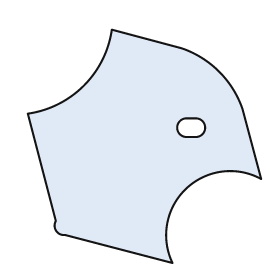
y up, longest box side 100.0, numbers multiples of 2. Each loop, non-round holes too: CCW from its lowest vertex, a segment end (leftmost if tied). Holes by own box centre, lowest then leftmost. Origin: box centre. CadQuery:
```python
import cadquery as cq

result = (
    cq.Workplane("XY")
    .moveTo(12.0, -50.0)
    .threePointArc((18.0, -18.0), (50.0, -14.0))
    .lineTo(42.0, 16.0)
    .threePointArc((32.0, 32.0), (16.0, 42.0))
    .lineTo(-14.0, 50.0)
    .threePointArc((-26.0, 26.0), (-50.0, 14.0))
    .lineTo(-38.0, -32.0)
    .threePointArc((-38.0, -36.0), (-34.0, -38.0))
    .close()
    .moveTo(18.0, 4.0)
    .lineTo(22.0, 4.0)
    .threePointArc((26.0, 8.0), (22.0, 12.0))
    .lineTo(18.0, 12.0)
    .threePointArc((14.0, 8.0), (18.0, 4.0))
    .close()
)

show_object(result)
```